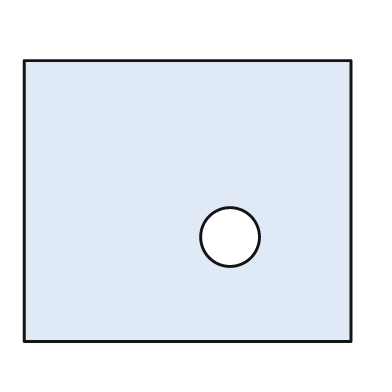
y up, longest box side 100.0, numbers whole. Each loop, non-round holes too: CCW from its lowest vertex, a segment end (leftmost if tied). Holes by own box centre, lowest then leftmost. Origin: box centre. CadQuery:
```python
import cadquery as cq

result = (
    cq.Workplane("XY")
    .moveTo(-50.0, -43.0)
    .lineTo(50.0, -43.0)
    .lineTo(50.0, 43.0)
    .lineTo(-50.0, 43.0)
    .close()
    .moveTo(13.0, -11.0)
    .circle(9.0)
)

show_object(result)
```